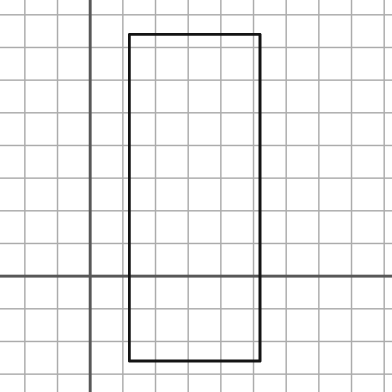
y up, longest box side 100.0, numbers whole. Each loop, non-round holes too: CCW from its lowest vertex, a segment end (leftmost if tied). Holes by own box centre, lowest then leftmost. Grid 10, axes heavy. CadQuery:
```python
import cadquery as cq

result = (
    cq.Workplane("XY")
    .moveTo(12.0, -26.0)
    .lineTo(52.0, -26.0)
    .lineTo(52.0, 74.0)
    .lineTo(12.0, 74.0)
    .close()
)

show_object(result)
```